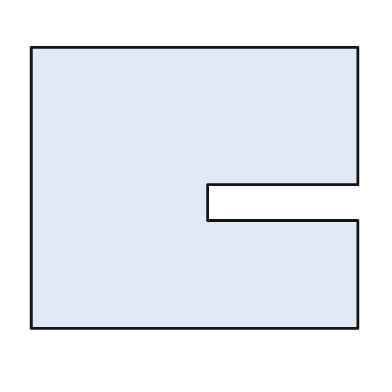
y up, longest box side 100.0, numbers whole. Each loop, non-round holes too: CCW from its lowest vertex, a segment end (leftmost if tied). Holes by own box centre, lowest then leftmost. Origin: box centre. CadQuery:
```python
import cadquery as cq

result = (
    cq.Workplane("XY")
    .moveTo(-50.0, -43.0)
    .lineTo(50.0, -43.0)
    .lineTo(50.0, -10.0)
    .lineTo(4.0, -10.0)
    .lineTo(4.0, 1.0)
    .lineTo(50.0, 1.0)
    .lineTo(50.0, 43.0)
    .lineTo(-50.0, 43.0)
    .close()
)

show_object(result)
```